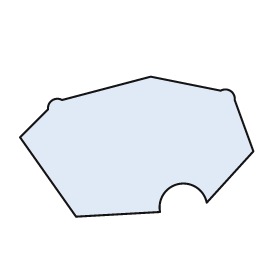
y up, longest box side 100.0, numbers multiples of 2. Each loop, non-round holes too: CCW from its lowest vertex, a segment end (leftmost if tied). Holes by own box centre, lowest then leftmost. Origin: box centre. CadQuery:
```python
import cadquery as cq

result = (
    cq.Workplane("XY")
    .moveTo(-26.0, -30.0)
    .lineTo(10.0, -28.0)
    .threePointArc((18.0, -16.0), (30.0, -24.0))
    .lineTo(50.0, -2.0)
    .lineTo(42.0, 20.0)
    .threePointArc((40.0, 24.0), (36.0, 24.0))
    .lineTo(6.0, 30.0)
    .lineTo(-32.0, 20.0)
    .threePointArc((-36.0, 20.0), (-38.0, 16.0))
    .lineTo(-50.0, 4.0)
    .close()
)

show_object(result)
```